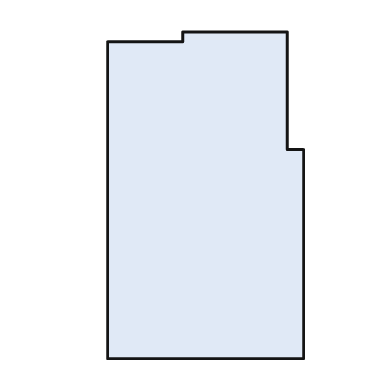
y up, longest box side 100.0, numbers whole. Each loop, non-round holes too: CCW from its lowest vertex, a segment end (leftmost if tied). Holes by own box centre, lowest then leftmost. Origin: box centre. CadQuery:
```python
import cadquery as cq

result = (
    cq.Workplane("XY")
    .moveTo(-30.0, -50.0)
    .lineTo(30.0, -50.0)
    .lineTo(30.0, 14.0)
    .lineTo(25.0, 14.0)
    .lineTo(25.0, 50.0)
    .lineTo(-7.0, 50.0)
    .lineTo(-7.0, 47.0)
    .lineTo(-30.0, 47.0)
    .close()
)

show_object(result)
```